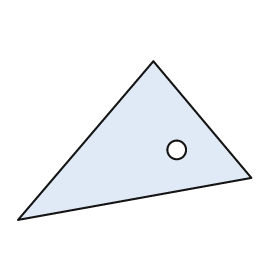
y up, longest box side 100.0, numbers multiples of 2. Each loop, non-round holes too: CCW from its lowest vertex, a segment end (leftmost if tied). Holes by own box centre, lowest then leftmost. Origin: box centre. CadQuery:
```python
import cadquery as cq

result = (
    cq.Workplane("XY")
    .moveTo(-50.0, -34.0)
    .lineTo(50.0, -16.0)
    .lineTo(8.0, 34.0)
    .close()
    .moveTo(18.0, -4.0)
    .circle(4.0)
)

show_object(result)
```